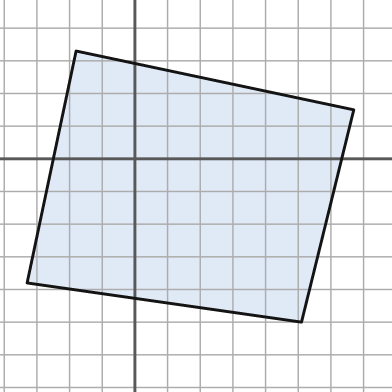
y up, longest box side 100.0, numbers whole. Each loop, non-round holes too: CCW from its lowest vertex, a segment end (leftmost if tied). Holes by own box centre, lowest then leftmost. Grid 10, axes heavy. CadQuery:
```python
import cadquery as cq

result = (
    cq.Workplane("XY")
    .moveTo(51.0, -50.0)
    .lineTo(67.0, 15.0)
    .lineTo(-18.0, 33.0)
    .lineTo(-33.0, -38.0)
    .close()
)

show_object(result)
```